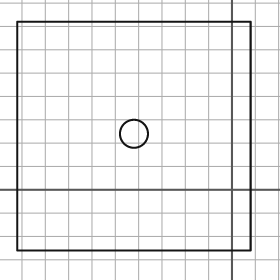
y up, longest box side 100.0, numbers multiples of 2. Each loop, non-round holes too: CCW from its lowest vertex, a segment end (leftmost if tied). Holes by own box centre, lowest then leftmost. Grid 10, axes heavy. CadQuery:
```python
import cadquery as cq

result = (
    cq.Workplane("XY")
    .moveTo(-92.0, -26.0)
    .lineTo(8.0, -26.0)
    .lineTo(8.0, 72.0)
    .lineTo(-92.0, 72.0)
    .close()
    .moveTo(-42.0, 24.0)
    .circle(6.0)
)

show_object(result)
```